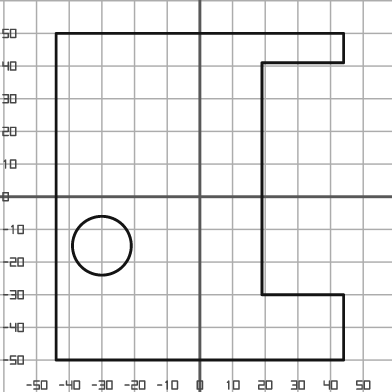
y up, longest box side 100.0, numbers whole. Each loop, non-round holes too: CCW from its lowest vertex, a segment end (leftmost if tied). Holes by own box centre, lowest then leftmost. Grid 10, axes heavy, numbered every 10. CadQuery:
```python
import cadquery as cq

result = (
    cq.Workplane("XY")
    .moveTo(-44.0, -50.0)
    .lineTo(44.0, -50.0)
    .lineTo(44.0, -30.0)
    .lineTo(19.0, -30.0)
    .lineTo(19.0, 41.0)
    .lineTo(44.0, 41.0)
    .lineTo(44.0, 50.0)
    .lineTo(-44.0, 50.0)
    .close()
    .moveTo(-30.0, -15.0)
    .circle(9.0)
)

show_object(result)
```